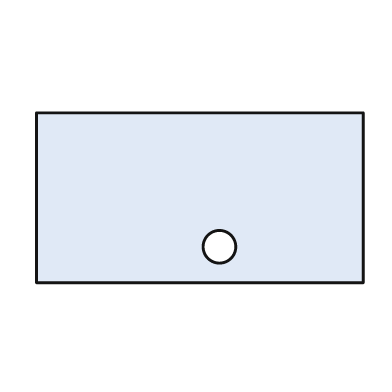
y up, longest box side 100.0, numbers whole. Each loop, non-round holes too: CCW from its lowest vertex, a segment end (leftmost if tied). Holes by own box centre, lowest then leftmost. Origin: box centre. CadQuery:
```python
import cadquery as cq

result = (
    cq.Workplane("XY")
    .moveTo(-50.0, -26.0)
    .lineTo(50.0, -26.0)
    .lineTo(50.0, 26.0)
    .lineTo(-50.0, 26.0)
    .close()
    .moveTo(6.0, -15.0)
    .circle(5.0)
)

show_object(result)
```